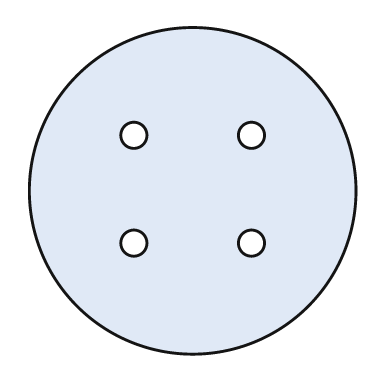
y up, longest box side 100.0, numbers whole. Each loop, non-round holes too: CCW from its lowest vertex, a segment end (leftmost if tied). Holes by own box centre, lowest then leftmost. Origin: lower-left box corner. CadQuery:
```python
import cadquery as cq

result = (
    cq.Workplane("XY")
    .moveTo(50.0, 50.0)
    .circle(50.0)
    .moveTo(32.0, 34.0)
    .circle(4.0)
    .moveTo(68.0, 34.0)
    .circle(4.0)
    .moveTo(32.0, 67.0)
    .circle(4.0)
    .moveTo(68.0, 67.0)
    .circle(4.0)
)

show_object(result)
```